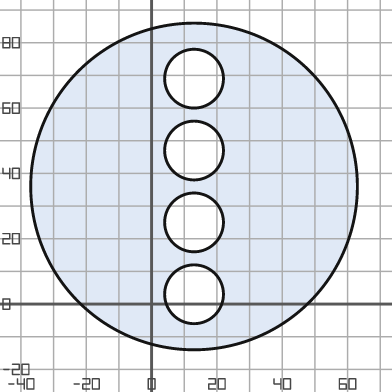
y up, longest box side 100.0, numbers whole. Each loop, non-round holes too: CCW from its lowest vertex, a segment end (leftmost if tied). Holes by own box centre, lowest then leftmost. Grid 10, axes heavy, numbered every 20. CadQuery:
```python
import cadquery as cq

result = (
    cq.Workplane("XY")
    .moveTo(13.0, 36.0)
    .circle(50.0)
    .moveTo(13.0, 3.0)
    .circle(9.0)
    .moveTo(13.0, 25.0)
    .circle(9.0)
    .moveTo(13.0, 47.0)
    .circle(9.0)
    .moveTo(13.0, 69.0)
    .circle(9.0)
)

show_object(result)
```